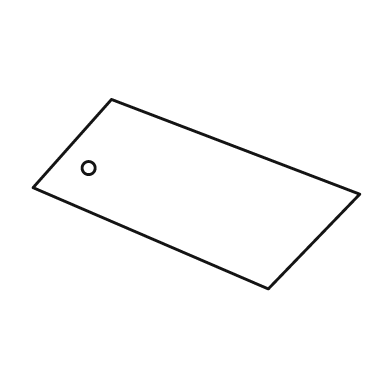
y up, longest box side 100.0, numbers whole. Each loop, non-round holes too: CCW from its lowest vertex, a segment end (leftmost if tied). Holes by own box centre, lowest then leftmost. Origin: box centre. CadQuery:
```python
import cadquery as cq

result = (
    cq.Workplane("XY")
    .moveTo(22.0, -29.0)
    .lineTo(50.0, 0.0)
    .lineTo(-26.0, 29.0)
    .lineTo(-50.0, 2.0)
    .close()
    .moveTo(-33.0, 8.0)
    .circle(2.0)
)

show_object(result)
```